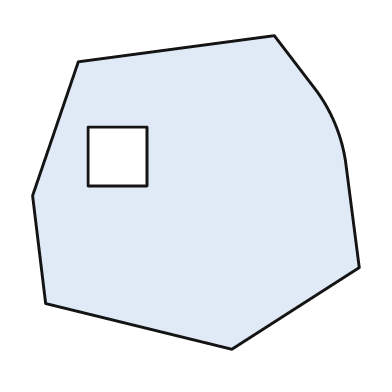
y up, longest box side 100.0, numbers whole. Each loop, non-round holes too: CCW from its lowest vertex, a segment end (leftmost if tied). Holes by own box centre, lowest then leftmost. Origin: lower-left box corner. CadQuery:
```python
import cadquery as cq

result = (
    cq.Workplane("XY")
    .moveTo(61.0, 0.0)
    .lineTo(100.0, 25.0)
    .lineTo(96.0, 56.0)
    .threePointArc((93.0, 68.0), (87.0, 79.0))
    .lineTo(74.0, 96.0)
    .lineTo(14.0, 88.0)
    .lineTo(0.0, 47.0)
    .lineTo(4.0, 14.0)
    .close()
    .moveTo(17.0, 50.0)
    .lineTo(35.0, 50.0)
    .lineTo(35.0, 68.0)
    .lineTo(17.0, 68.0)
    .close()
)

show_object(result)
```